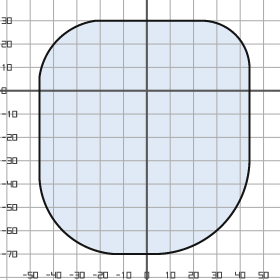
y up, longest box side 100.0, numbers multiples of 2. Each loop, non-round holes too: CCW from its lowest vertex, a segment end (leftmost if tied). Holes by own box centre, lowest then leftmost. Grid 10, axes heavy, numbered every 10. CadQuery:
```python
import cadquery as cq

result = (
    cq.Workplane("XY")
    .moveTo(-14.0, -70.0)
    .lineTo(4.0, -70.0)
    .threePointArc((32.0, -58.0), (44.0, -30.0))
    .lineTo(44.0, 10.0)
    .threePointArc((38.0, 24.0), (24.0, 30.0))
    .lineTo(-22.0, 30.0)
    .threePointArc((-38.0, 22.0), (-46.0, 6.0))
    .lineTo(-46.0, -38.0)
    .threePointArc((-36.0, -60.0), (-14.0, -70.0))
    .close()
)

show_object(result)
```